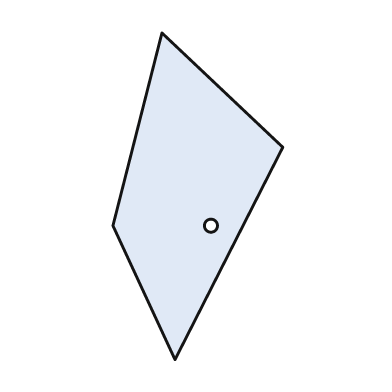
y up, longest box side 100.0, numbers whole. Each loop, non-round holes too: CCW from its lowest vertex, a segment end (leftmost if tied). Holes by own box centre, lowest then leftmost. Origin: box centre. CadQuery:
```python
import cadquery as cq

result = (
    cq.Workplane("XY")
    .moveTo(-7.0, -50.0)
    .lineTo(26.0, 15.0)
    .lineTo(-11.0, 50.0)
    .lineTo(-26.0, -9.0)
    .close()
    .moveTo(4.0, -9.0)
    .circle(2.0)
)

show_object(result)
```